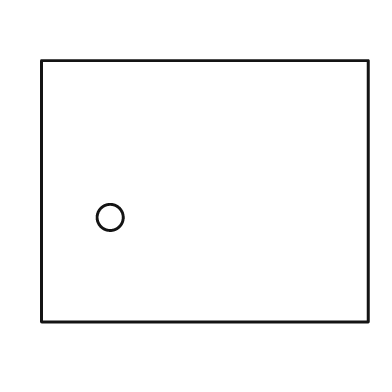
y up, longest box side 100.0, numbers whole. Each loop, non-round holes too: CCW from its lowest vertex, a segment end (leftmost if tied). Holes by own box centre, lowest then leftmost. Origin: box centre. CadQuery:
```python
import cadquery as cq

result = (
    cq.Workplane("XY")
    .moveTo(-50.0, -40.0)
    .lineTo(50.0, -40.0)
    .lineTo(50.0, 40.0)
    .lineTo(-50.0, 40.0)
    .close()
    .moveTo(-29.0, -8.0)
    .circle(4.0)
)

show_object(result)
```